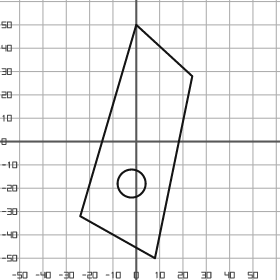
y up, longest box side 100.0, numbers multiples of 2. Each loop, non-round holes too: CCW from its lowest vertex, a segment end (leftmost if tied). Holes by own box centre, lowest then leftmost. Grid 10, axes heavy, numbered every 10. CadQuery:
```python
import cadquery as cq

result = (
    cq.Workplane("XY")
    .moveTo(8.0, -50.0)
    .lineTo(24.0, 28.0)
    .lineTo(0.0, 50.0)
    .lineTo(-24.0, -32.0)
    .close()
    .moveTo(-2.0, -18.0)
    .circle(6.0)
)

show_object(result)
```